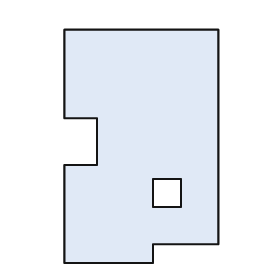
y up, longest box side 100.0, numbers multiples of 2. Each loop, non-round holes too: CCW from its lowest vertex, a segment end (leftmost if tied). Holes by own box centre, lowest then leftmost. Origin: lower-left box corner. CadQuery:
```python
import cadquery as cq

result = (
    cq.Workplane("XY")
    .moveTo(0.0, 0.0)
    .lineTo(38.0, 0.0)
    .lineTo(38.0, 8.0)
    .lineTo(66.0, 8.0)
    .lineTo(66.0, 100.0)
    .lineTo(0.0, 100.0)
    .lineTo(0.0, 62.0)
    .lineTo(14.0, 62.0)
    .lineTo(14.0, 42.0)
    .lineTo(0.0, 42.0)
    .close()
    .moveTo(38.0, 24.0)
    .lineTo(50.0, 24.0)
    .lineTo(50.0, 36.0)
    .lineTo(38.0, 36.0)
    .close()
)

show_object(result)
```